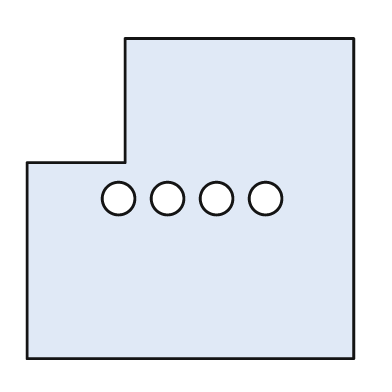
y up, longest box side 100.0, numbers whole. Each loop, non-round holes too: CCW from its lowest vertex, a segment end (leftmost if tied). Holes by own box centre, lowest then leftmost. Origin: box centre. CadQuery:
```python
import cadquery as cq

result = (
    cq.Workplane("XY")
    .moveTo(-50.0, -49.0)
    .lineTo(50.0, -49.0)
    .lineTo(50.0, 49.0)
    .lineTo(-20.0, 49.0)
    .lineTo(-20.0, 11.0)
    .lineTo(-50.0, 11.0)
    .close()
    .moveTo(-22.0, 0.0)
    .circle(5.0)
    .moveTo(-7.0, 0.0)
    .circle(5.0)
    .moveTo(8.0, 0.0)
    .circle(5.0)
    .moveTo(23.0, 0.0)
    .circle(5.0)
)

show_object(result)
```